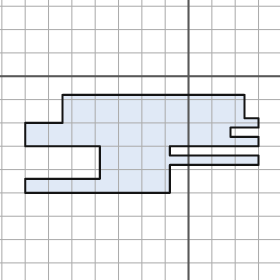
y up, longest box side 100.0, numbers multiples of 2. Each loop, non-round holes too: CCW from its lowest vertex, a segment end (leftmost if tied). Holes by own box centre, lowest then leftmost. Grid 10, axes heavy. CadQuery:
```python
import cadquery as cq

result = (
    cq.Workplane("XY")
    .moveTo(-70.0, -50.0)
    .lineTo(-8.0, -50.0)
    .lineTo(-8.0, -38.0)
    .lineTo(30.0, -38.0)
    .lineTo(30.0, -34.0)
    .lineTo(-8.0, -34.0)
    .lineTo(-8.0, -30.0)
    .lineTo(30.0, -30.0)
    .lineTo(30.0, -26.0)
    .lineTo(18.0, -26.0)
    .lineTo(18.0, -22.0)
    .lineTo(30.0, -22.0)
    .lineTo(30.0, -18.0)
    .lineTo(24.0, -18.0)
    .lineTo(24.0, -8.0)
    .lineTo(-54.0, -8.0)
    .lineTo(-54.0, -20.0)
    .lineTo(-70.0, -20.0)
    .lineTo(-70.0, -30.0)
    .lineTo(-38.0, -30.0)
    .lineTo(-38.0, -44.0)
    .lineTo(-70.0, -44.0)
    .close()
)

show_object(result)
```